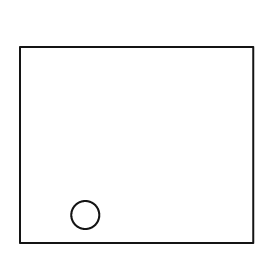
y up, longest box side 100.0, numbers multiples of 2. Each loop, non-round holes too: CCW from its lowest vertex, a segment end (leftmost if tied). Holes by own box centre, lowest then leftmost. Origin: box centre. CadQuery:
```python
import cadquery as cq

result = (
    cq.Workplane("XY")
    .moveTo(-50.0, -42.0)
    .lineTo(50.0, -42.0)
    .lineTo(50.0, 42.0)
    .lineTo(-50.0, 42.0)
    .close()
    .moveTo(-22.0, -30.0)
    .circle(6.0)
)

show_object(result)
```